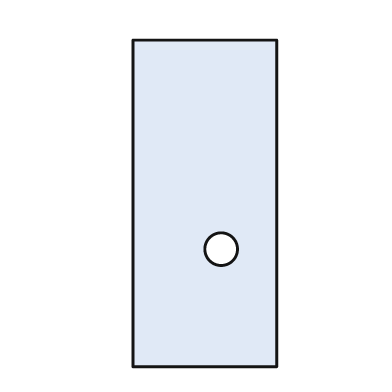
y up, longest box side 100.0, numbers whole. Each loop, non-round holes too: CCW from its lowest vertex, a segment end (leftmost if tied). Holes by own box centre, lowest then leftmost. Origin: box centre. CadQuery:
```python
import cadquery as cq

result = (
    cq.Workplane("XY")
    .moveTo(-22.0, -50.0)
    .lineTo(22.0, -50.0)
    .lineTo(22.0, 50.0)
    .lineTo(-22.0, 50.0)
    .close()
    .moveTo(5.0, -14.0)
    .circle(5.0)
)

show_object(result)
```